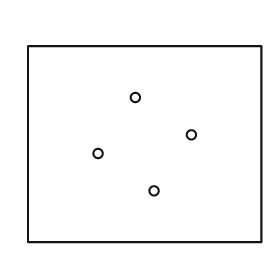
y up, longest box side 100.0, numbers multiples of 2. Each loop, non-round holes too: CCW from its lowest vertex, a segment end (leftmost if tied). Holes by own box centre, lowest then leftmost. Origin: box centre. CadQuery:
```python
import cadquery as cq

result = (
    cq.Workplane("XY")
    .moveTo(-50.0, -42.0)
    .lineTo(50.0, -42.0)
    .lineTo(50.0, 42.0)
    .lineTo(-50.0, 42.0)
    .close()
    .moveTo(4.0, -20.0)
    .circle(2.0)
    .moveTo(-20.0, -4.0)
    .circle(2.0)
    .moveTo(20.0, 4.0)
    .circle(2.0)
    .moveTo(-4.0, 20.0)
    .circle(2.0)
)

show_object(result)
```